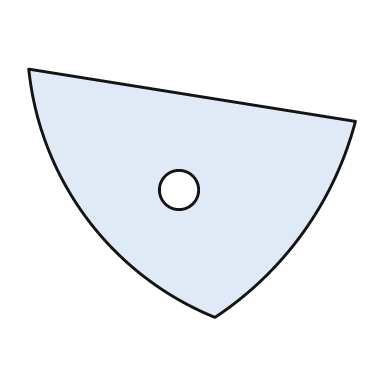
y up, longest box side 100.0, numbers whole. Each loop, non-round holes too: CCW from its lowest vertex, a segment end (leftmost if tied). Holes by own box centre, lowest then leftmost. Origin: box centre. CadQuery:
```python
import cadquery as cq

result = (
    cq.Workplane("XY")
    .moveTo(7.0, -38.0)
    .threePointArc((34.0, -12.0), (50.0, 22.0))
    .lineTo(-50.0, 38.0)
    .threePointArc((-32.0, -8.0), (7.0, -38.0))
    .close()
    .moveTo(-4.0, 1.0)
    .circle(6.0)
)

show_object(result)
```